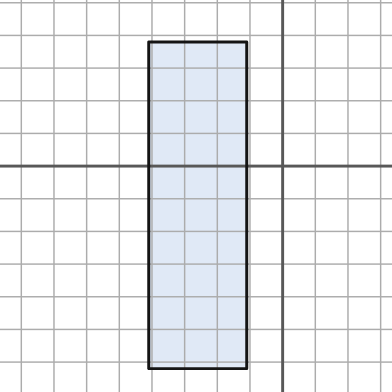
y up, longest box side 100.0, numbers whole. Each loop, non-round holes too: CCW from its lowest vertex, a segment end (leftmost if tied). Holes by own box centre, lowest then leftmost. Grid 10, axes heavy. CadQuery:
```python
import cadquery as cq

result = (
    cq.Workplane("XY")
    .moveTo(-41.0, -62.0)
    .lineTo(-11.0, -62.0)
    .lineTo(-11.0, 38.0)
    .lineTo(-41.0, 38.0)
    .close()
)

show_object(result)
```